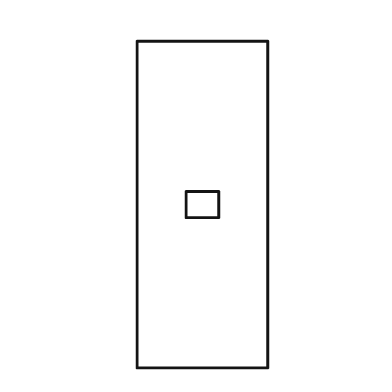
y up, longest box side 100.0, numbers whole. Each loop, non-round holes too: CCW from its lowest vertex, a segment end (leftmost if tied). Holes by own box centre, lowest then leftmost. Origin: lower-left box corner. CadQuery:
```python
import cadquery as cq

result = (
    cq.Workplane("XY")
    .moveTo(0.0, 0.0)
    .lineTo(40.0, 0.0)
    .lineTo(40.0, 100.0)
    .lineTo(0.0, 100.0)
    .close()
    .moveTo(15.0, 46.0)
    .lineTo(25.0, 46.0)
    .lineTo(25.0, 54.0)
    .lineTo(15.0, 54.0)
    .close()
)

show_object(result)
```